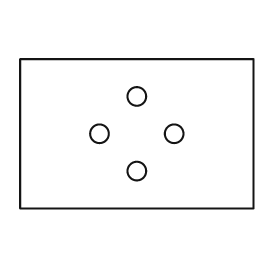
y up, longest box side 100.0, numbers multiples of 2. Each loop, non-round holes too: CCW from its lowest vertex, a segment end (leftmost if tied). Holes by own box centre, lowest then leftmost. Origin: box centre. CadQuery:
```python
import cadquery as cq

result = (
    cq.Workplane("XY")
    .moveTo(-50.0, -32.0)
    .lineTo(50.0, -32.0)
    .lineTo(50.0, 32.0)
    .lineTo(-50.0, 32.0)
    .close()
    .moveTo(0.0, -16.0)
    .circle(4.0)
    .moveTo(-16.0, 0.0)
    .circle(4.0)
    .moveTo(16.0, 0.0)
    .circle(4.0)
    .moveTo(0.0, 16.0)
    .circle(4.0)
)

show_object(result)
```